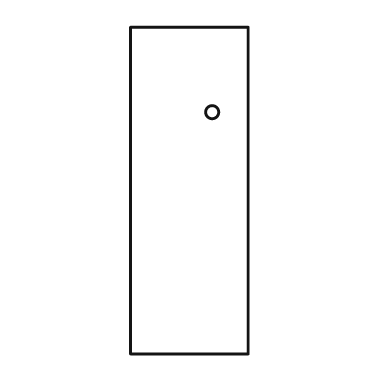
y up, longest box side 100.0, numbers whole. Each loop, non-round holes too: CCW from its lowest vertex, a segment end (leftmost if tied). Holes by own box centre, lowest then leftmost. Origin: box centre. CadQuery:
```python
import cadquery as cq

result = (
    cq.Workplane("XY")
    .moveTo(-18.0, -50.0)
    .lineTo(18.0, -50.0)
    .lineTo(18.0, 50.0)
    .lineTo(-18.0, 50.0)
    .close()
    .moveTo(7.0, 24.0)
    .circle(2.0)
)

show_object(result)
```